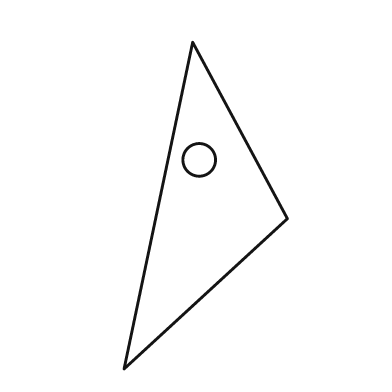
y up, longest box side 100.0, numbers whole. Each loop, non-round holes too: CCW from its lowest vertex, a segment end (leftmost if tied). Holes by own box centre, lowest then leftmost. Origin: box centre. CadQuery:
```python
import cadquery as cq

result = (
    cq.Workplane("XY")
    .moveTo(-25.0, -50.0)
    .lineTo(25.0, -4.0)
    .lineTo(-4.0, 50.0)
    .close()
    .moveTo(-2.0, 14.0)
    .circle(5.0)
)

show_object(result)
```